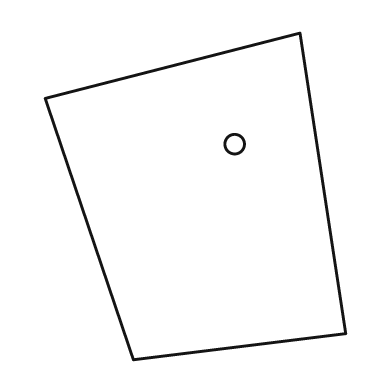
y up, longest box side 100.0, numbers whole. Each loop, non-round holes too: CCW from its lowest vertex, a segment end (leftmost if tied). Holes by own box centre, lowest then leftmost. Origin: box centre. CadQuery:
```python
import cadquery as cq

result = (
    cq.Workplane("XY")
    .moveTo(-19.0, -50.0)
    .lineTo(46.0, -42.0)
    .lineTo(32.0, 50.0)
    .lineTo(-46.0, 30.0)
    .close()
    .moveTo(12.0, 16.0)
    .circle(3.0)
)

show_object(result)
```